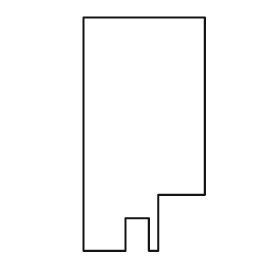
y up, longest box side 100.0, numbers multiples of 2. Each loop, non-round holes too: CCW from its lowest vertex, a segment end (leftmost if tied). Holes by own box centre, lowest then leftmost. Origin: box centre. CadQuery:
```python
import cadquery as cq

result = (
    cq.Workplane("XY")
    .moveTo(-26.0, -50.0)
    .lineTo(-8.0, -50.0)
    .lineTo(-8.0, -36.0)
    .lineTo(2.0, -36.0)
    .lineTo(2.0, -50.0)
    .lineTo(6.0, -50.0)
    .lineTo(6.0, -26.0)
    .lineTo(26.0, -26.0)
    .lineTo(26.0, 50.0)
    .lineTo(-26.0, 50.0)
    .close()
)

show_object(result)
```